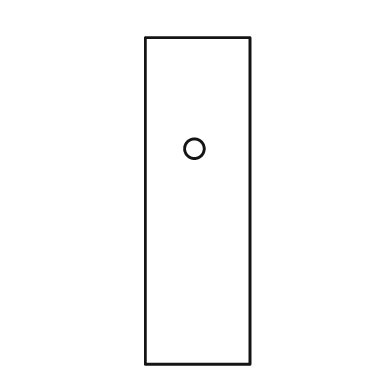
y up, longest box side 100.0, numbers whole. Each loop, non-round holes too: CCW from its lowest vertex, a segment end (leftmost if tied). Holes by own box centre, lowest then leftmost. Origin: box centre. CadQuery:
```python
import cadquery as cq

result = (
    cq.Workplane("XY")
    .moveTo(-16.0, -50.0)
    .lineTo(16.0, -50.0)
    .lineTo(16.0, 50.0)
    .lineTo(-16.0, 50.0)
    .close()
    .moveTo(-1.0, 16.0)
    .circle(3.0)
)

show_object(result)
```